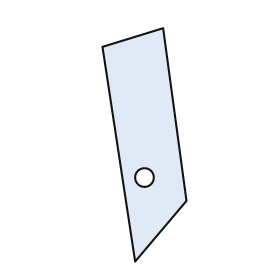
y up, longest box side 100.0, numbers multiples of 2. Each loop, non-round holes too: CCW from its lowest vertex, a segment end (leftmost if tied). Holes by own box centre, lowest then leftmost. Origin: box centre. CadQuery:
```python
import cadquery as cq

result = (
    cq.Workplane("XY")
    .moveTo(-4.0, -50.0)
    .lineTo(18.0, -24.0)
    .lineTo(8.0, 50.0)
    .lineTo(-18.0, 42.0)
    .close()
    .moveTo(0.0, -14.0)
    .circle(4.0)
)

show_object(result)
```